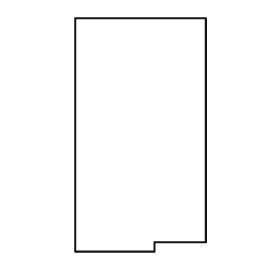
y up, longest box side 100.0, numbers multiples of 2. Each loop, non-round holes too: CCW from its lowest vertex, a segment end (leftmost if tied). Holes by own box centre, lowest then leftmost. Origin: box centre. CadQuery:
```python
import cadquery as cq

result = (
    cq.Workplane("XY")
    .moveTo(-28.0, -50.0)
    .lineTo(6.0, -50.0)
    .lineTo(6.0, -46.0)
    .lineTo(28.0, -46.0)
    .lineTo(28.0, 50.0)
    .lineTo(-28.0, 50.0)
    .close()
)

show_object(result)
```